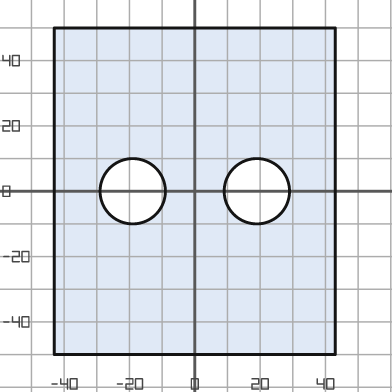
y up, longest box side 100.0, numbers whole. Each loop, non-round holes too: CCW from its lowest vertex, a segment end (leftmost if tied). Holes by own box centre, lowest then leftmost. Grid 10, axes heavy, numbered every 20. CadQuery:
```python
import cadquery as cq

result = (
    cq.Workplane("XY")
    .moveTo(-43.0, -50.0)
    .lineTo(43.0, -50.0)
    .lineTo(43.0, 50.0)
    .lineTo(-43.0, 50.0)
    .close()
    .moveTo(-19.0, 0.0)
    .circle(10.0)
    .moveTo(19.0, 0.0)
    .circle(10.0)
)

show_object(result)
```